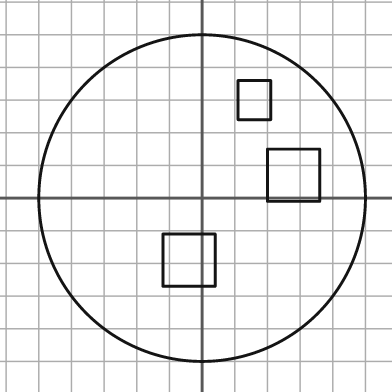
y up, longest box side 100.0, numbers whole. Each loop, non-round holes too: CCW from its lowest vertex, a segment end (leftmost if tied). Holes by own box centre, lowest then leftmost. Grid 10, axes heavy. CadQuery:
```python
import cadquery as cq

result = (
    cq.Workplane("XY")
    .moveTo(0.0, 0.0)
    .circle(50.0)
    .moveTo(-12.0, -27.0)
    .lineTo(4.0, -27.0)
    .lineTo(4.0, -11.0)
    .lineTo(-12.0, -11.0)
    .close()
    .moveTo(20.0, -1.0)
    .lineTo(36.0, -1.0)
    .lineTo(36.0, 15.0)
    .lineTo(20.0, 15.0)
    .close()
    .moveTo(11.0, 24.0)
    .lineTo(21.0, 24.0)
    .lineTo(21.0, 36.0)
    .lineTo(11.0, 36.0)
    .close()
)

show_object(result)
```